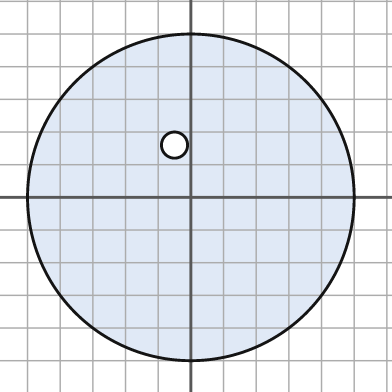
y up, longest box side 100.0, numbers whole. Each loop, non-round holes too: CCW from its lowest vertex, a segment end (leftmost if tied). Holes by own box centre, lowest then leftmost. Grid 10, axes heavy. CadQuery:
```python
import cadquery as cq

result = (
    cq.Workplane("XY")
    .moveTo(0.0, 0.0)
    .circle(50.0)
    .moveTo(-5.0, 16.0)
    .circle(4.0)
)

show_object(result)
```